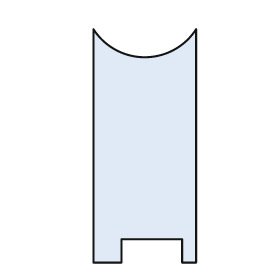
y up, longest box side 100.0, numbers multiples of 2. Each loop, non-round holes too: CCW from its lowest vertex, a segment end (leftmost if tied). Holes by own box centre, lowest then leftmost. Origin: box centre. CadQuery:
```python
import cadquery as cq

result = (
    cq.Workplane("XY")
    .moveTo(-22.0, -50.0)
    .lineTo(-10.0, -50.0)
    .lineTo(-10.0, -40.0)
    .lineTo(16.0, -40.0)
    .lineTo(16.0, -50.0)
    .lineTo(22.0, -50.0)
    .lineTo(22.0, 50.0)
    .threePointArc((0.0, 38.0), (-22.0, 50.0))
    .close()
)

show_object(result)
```